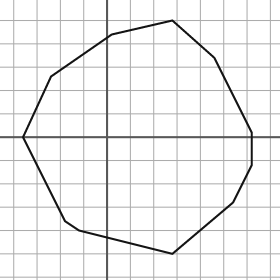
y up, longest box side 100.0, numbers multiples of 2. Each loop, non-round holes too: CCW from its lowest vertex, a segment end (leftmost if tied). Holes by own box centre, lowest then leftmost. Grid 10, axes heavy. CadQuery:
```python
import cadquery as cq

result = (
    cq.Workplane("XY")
    .moveTo(28.0, -50.0)
    .lineTo(54.0, -28.0)
    .lineTo(62.0, -12.0)
    .lineTo(62.0, 2.0)
    .lineTo(46.0, 34.0)
    .lineTo(28.0, 50.0)
    .lineTo(2.0, 44.0)
    .lineTo(-24.0, 26.0)
    .lineTo(-36.0, 0.0)
    .lineTo(-18.0, -36.0)
    .lineTo(-12.0, -40.0)
    .close()
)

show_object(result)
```